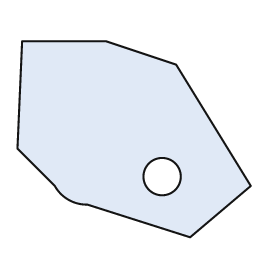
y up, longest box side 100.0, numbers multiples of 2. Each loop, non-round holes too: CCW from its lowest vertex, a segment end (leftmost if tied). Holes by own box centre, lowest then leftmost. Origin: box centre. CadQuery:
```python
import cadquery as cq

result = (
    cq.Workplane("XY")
    .moveTo(24.0, -42.0)
    .lineTo(50.0, -20.0)
    .lineTo(18.0, 32.0)
    .lineTo(-12.0, 42.0)
    .lineTo(-48.0, 42.0)
    .lineTo(-50.0, -4.0)
    .lineTo(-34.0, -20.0)
    .threePointArc((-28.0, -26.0), (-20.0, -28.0))
    .close()
    .moveTo(12.0, -16.0)
    .circle(8.0)
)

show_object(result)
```